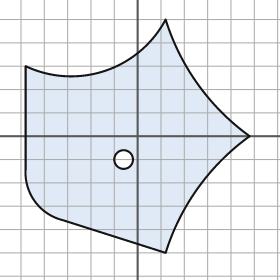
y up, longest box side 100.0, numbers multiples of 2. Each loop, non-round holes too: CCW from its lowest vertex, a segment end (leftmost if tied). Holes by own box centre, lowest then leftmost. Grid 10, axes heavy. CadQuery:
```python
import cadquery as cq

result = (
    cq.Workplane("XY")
    .moveTo(12.0, -50.0)
    .threePointArc((26.0, -22.0), (48.0, 0.0))
    .threePointArc((26.0, 22.0), (12.0, 50.0))
    .threePointArc((-14.0, 28.0), (-48.0, 30.0))
    .lineTo(-48.0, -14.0)
    .threePointArc((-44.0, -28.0), (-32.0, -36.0))
    .close()
    .moveTo(-6.0, -10.0)
    .circle(4.0)
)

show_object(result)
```